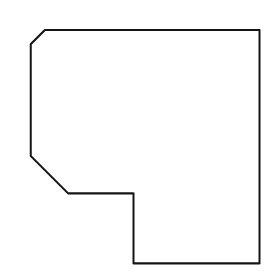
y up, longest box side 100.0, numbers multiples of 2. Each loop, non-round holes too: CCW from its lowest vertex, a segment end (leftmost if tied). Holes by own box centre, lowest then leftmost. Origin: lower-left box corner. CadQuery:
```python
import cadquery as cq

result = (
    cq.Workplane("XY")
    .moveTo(44.0, 0.0)
    .lineTo(98.0, 0.0)
    .lineTo(98.0, 100.0)
    .lineTo(6.0, 100.0)
    .lineTo(0.0, 94.0)
    .lineTo(0.0, 46.0)
    .lineTo(16.0, 30.0)
    .lineTo(44.0, 30.0)
    .close()
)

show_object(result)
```